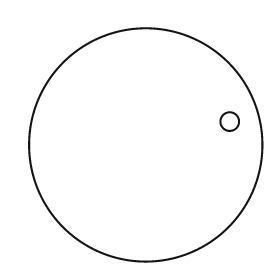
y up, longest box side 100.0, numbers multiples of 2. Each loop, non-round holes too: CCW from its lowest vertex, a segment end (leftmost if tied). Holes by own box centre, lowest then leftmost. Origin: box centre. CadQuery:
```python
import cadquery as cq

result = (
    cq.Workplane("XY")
    .moveTo(0.0, 0.0)
    .circle(50.0)
    .moveTo(36.0, 10.0)
    .circle(4.0)
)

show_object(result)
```